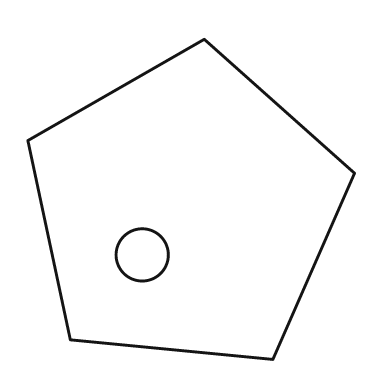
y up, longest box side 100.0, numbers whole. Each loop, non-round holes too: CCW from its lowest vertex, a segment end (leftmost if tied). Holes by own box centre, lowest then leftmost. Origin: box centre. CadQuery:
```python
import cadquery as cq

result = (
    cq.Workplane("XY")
    .moveTo(25.0, -49.0)
    .lineTo(50.0, 8.0)
    .lineTo(4.0, 49.0)
    .lineTo(-50.0, 18.0)
    .lineTo(-37.0, -43.0)
    .close()
    .moveTo(-15.0, -17.0)
    .circle(8.0)
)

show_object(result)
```